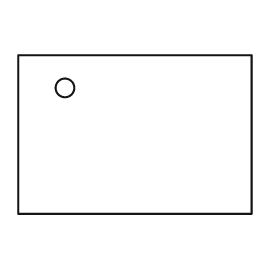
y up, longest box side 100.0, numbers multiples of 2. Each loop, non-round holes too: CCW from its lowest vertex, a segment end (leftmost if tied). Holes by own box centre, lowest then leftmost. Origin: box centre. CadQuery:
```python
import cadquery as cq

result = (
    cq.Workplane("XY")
    .moveTo(-50.0, -34.0)
    .lineTo(50.0, -34.0)
    .lineTo(50.0, 34.0)
    .lineTo(-50.0, 34.0)
    .close()
    .moveTo(-30.0, 20.0)
    .circle(4.0)
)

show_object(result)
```